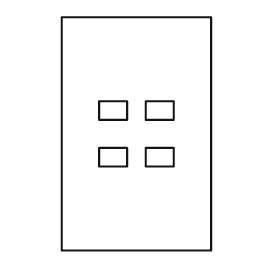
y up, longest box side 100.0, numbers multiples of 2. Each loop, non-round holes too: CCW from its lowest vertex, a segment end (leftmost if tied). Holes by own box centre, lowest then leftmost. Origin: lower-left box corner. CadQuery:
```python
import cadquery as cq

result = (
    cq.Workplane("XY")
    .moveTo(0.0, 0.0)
    .lineTo(64.0, 0.0)
    .lineTo(64.0, 100.0)
    .lineTo(0.0, 100.0)
    .close()
    .moveTo(16.0, 36.0)
    .lineTo(28.0, 36.0)
    .lineTo(28.0, 44.0)
    .lineTo(16.0, 44.0)
    .close()
    .moveTo(36.0, 36.0)
    .lineTo(48.0, 36.0)
    .lineTo(48.0, 44.0)
    .lineTo(36.0, 44.0)
    .close()
    .moveTo(16.0, 56.0)
    .lineTo(28.0, 56.0)
    .lineTo(28.0, 64.0)
    .lineTo(16.0, 64.0)
    .close()
    .moveTo(36.0, 56.0)
    .lineTo(48.0, 56.0)
    .lineTo(48.0, 64.0)
    .lineTo(36.0, 64.0)
    .close()
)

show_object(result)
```